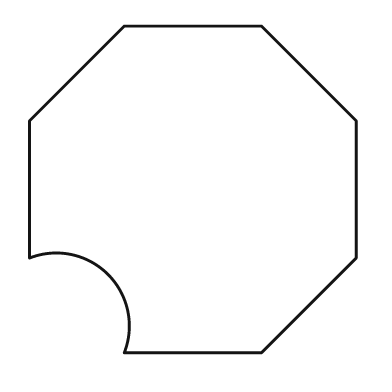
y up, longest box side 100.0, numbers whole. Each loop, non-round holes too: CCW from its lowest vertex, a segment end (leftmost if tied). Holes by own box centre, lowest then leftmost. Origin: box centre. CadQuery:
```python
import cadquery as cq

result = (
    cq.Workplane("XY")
    .moveTo(-21.0, -50.0)
    .lineTo(21.0, -50.0)
    .lineTo(50.0, -21.0)
    .lineTo(50.0, 21.0)
    .lineTo(21.0, 50.0)
    .lineTo(-21.0, 50.0)
    .lineTo(-50.0, 21.0)
    .lineTo(-50.0, -21.0)
    .threePointArc((-26.0, -26.0), (-21.0, -50.0))
    .close()
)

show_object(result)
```